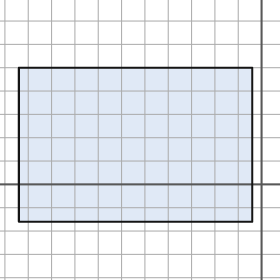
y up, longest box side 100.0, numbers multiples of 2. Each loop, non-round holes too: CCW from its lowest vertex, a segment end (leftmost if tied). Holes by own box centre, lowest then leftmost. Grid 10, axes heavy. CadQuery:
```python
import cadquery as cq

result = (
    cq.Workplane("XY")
    .moveTo(-104.0, -16.0)
    .lineTo(-4.0, -16.0)
    .lineTo(-4.0, 50.0)
    .lineTo(-104.0, 50.0)
    .close()
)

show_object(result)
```